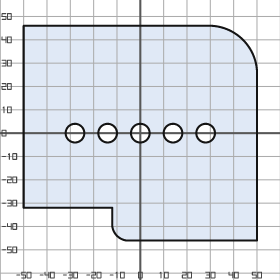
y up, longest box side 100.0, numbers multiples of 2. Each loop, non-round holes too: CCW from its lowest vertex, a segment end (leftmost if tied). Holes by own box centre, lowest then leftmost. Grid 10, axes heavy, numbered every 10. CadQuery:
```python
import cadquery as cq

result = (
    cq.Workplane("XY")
    .moveTo(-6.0, -46.0)
    .lineTo(50.0, -46.0)
    .lineTo(50.0, 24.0)
    .threePointArc((44.0, 40.0), (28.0, 46.0))
    .lineTo(-50.0, 46.0)
    .lineTo(-50.0, -32.0)
    .lineTo(-12.0, -32.0)
    .lineTo(-12.0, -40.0)
    .threePointArc((-10.0, -44.0), (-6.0, -46.0))
    .close()
    .moveTo(-28.0, 0.0)
    .circle(4.0)
    .moveTo(-14.0, 0.0)
    .circle(4.0)
    .moveTo(0.0, 0.0)
    .circle(4.0)
    .moveTo(14.0, 0.0)
    .circle(4.0)
    .moveTo(28.0, 0.0)
    .circle(4.0)
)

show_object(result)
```